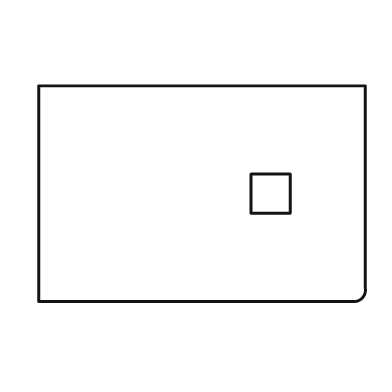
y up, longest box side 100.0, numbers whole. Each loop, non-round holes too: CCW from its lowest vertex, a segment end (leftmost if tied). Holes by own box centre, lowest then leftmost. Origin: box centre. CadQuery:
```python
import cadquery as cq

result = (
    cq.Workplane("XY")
    .moveTo(-50.0, -33.0)
    .lineTo(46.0, -33.0)
    .threePointArc((49.0, -32.0), (50.0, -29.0))
    .lineTo(50.0, 33.0)
    .lineTo(-50.0, 33.0)
    .close()
    .moveTo(15.0, -6.0)
    .lineTo(27.0, -6.0)
    .lineTo(27.0, 6.0)
    .lineTo(15.0, 6.0)
    .close()
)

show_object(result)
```